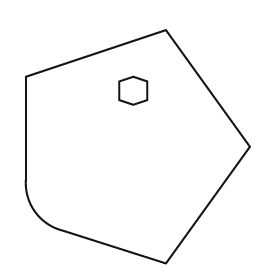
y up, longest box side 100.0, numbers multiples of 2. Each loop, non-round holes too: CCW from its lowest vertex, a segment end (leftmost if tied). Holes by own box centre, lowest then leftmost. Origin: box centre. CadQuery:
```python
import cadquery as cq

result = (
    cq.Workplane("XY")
    .moveTo(12.0, -50.0)
    .lineTo(48.0, 0.0)
    .lineTo(12.0, 50.0)
    .lineTo(-48.0, 30.0)
    .lineTo(-48.0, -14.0)
    .threePointArc((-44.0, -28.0), (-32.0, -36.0))
    .close()
    .moveTo(-2.0, 18.0)
    .lineTo(4.0, 20.0)
    .lineTo(4.0, 28.0)
    .lineTo(-2.0, 30.0)
    .lineTo(-8.0, 28.0)
    .lineTo(-8.0, 20.0)
    .close()
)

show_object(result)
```